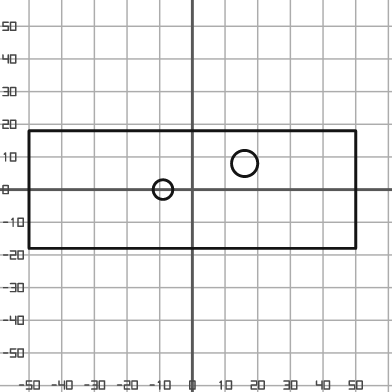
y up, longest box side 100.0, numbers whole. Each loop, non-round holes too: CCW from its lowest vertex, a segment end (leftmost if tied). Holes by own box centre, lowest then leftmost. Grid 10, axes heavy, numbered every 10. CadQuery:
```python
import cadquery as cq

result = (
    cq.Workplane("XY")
    .moveTo(-50.0, -18.0)
    .lineTo(50.0, -18.0)
    .lineTo(50.0, 18.0)
    .lineTo(-50.0, 18.0)
    .close()
    .moveTo(-9.0, 0.0)
    .circle(3.0)
    .moveTo(16.0, 8.0)
    .circle(4.0)
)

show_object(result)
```